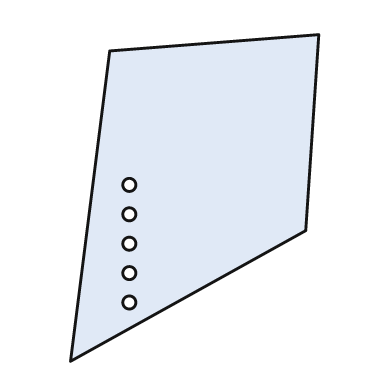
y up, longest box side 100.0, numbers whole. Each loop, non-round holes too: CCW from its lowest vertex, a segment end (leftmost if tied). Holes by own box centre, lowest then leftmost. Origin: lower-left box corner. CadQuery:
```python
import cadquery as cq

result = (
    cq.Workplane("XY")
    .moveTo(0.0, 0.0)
    .lineTo(72.0, 40.0)
    .lineTo(76.0, 100.0)
    .lineTo(12.0, 95.0)
    .close()
    .moveTo(18.0, 18.0)
    .circle(2.0)
    .moveTo(18.0, 27.0)
    .circle(2.0)
    .moveTo(18.0, 36.0)
    .circle(2.0)
    .moveTo(18.0, 45.0)
    .circle(2.0)
    .moveTo(18.0, 54.0)
    .circle(2.0)
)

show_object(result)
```